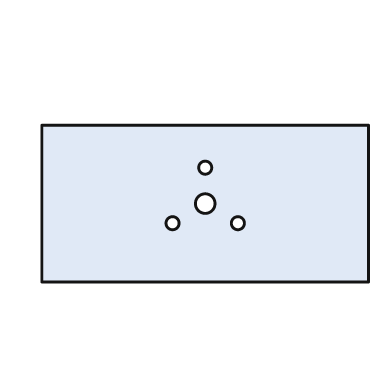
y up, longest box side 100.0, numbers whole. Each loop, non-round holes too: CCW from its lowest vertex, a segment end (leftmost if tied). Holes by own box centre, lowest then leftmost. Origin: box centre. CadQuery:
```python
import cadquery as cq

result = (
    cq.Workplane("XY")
    .moveTo(-50.0, -24.0)
    .lineTo(50.0, -24.0)
    .lineTo(50.0, 24.0)
    .lineTo(-50.0, 24.0)
    .close()
    .moveTo(-10.0, -6.0)
    .circle(2.0)
    .moveTo(10.0, -6.0)
    .circle(2.0)
    .moveTo(0.0, 0.0)
    .circle(3.0)
    .moveTo(0.0, 11.0)
    .circle(2.0)
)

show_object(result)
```